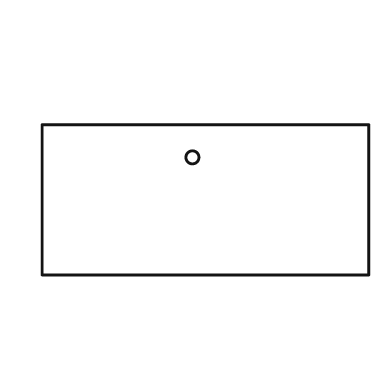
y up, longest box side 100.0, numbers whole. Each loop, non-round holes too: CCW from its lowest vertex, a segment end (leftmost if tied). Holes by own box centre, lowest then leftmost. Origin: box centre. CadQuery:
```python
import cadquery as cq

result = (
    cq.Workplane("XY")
    .moveTo(-50.0, -23.0)
    .lineTo(50.0, -23.0)
    .lineTo(50.0, 23.0)
    .lineTo(-50.0, 23.0)
    .close()
    .moveTo(-4.0, 13.0)
    .circle(2.0)
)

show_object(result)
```